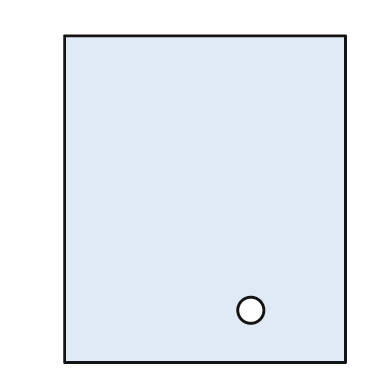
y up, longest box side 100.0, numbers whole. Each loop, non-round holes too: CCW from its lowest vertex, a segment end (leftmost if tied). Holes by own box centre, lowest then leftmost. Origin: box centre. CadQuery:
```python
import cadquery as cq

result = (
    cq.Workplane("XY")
    .moveTo(-43.0, -50.0)
    .lineTo(43.0, -50.0)
    .lineTo(43.0, 50.0)
    .lineTo(-43.0, 50.0)
    .close()
    .moveTo(14.0, -34.0)
    .circle(4.0)
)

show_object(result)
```